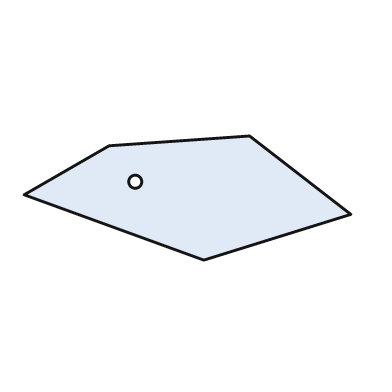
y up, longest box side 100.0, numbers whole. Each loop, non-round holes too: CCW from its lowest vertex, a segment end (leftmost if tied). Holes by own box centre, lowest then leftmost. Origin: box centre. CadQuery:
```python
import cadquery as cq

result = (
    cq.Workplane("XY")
    .moveTo(5.0, -19.0)
    .lineTo(50.0, -5.0)
    .lineTo(19.0, 19.0)
    .lineTo(-24.0, 16.0)
    .lineTo(-50.0, 1.0)
    .close()
    .moveTo(-16.0, 5.0)
    .circle(2.0)
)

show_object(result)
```